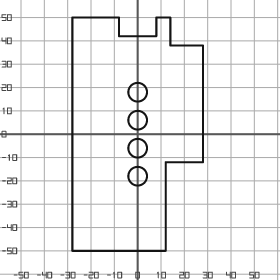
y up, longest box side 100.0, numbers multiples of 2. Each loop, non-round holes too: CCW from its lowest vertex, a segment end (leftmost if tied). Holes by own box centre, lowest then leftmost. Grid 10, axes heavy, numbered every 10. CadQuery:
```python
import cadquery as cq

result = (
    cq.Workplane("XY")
    .moveTo(-28.0, -50.0)
    .lineTo(12.0, -50.0)
    .lineTo(12.0, -12.0)
    .lineTo(28.0, -12.0)
    .lineTo(28.0, 38.0)
    .lineTo(14.0, 38.0)
    .lineTo(14.0, 50.0)
    .lineTo(8.0, 50.0)
    .lineTo(8.0, 42.0)
    .lineTo(-8.0, 42.0)
    .lineTo(-8.0, 50.0)
    .lineTo(-28.0, 50.0)
    .close()
    .moveTo(0.0, -18.0)
    .circle(4.0)
    .moveTo(0.0, -6.0)
    .circle(4.0)
    .moveTo(0.0, 6.0)
    .circle(4.0)
    .moveTo(0.0, 18.0)
    .circle(4.0)
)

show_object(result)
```